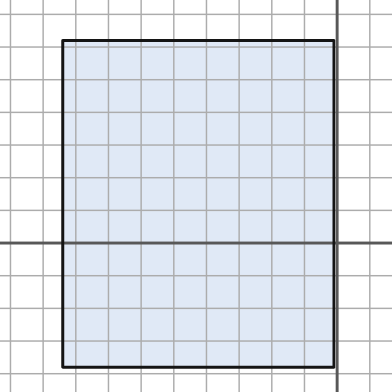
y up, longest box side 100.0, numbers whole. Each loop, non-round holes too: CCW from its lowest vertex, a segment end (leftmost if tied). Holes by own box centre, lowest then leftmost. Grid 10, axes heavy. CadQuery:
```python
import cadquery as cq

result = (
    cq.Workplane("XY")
    .moveTo(-84.0, -38.0)
    .lineTo(-1.0, -38.0)
    .lineTo(-1.0, 62.0)
    .lineTo(-84.0, 62.0)
    .close()
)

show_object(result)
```